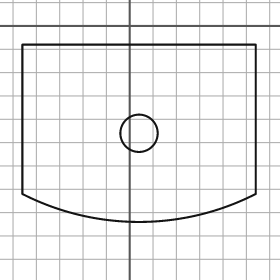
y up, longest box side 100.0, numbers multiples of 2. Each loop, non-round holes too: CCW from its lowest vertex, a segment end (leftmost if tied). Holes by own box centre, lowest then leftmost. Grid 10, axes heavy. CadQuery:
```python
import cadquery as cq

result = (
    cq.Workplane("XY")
    .moveTo(-46.0, -72.0)
    .threePointArc((4.0, -84.0), (54.0, -72.0))
    .lineTo(54.0, -8.0)
    .lineTo(-46.0, -8.0)
    .close()
    .moveTo(4.0, -46.0)
    .circle(8.0)
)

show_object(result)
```